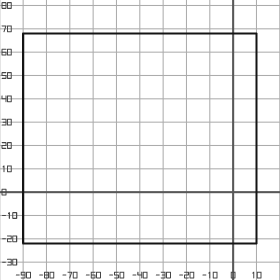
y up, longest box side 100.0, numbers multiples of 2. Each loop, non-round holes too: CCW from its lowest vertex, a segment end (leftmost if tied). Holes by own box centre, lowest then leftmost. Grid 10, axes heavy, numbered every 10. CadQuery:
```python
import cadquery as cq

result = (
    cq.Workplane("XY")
    .moveTo(-90.0, -22.0)
    .lineTo(10.0, -22.0)
    .lineTo(10.0, 68.0)
    .lineTo(-90.0, 68.0)
    .close()
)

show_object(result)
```